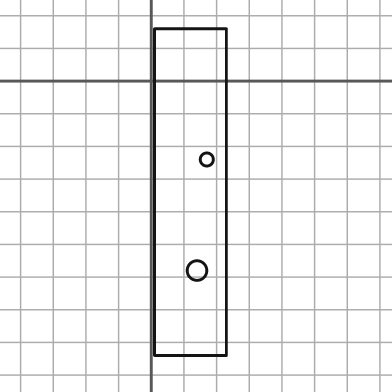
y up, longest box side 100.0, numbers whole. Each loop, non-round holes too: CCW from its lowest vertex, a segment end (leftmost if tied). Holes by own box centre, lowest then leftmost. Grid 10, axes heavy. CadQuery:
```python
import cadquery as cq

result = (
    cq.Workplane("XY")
    .moveTo(1.0, -84.0)
    .lineTo(23.0, -84.0)
    .lineTo(23.0, 16.0)
    .lineTo(1.0, 16.0)
    .close()
    .moveTo(14.0, -58.0)
    .circle(3.0)
    .moveTo(17.0, -24.0)
    .circle(2.0)
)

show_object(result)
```